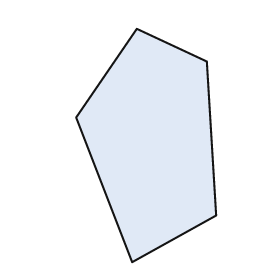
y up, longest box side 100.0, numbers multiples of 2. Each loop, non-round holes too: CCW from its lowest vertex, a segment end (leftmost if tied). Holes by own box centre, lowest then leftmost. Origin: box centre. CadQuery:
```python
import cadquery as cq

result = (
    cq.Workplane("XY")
    .moveTo(-6.0, -50.0)
    .lineTo(30.0, -30.0)
    .lineTo(26.0, 36.0)
    .lineTo(-4.0, 50.0)
    .lineTo(-30.0, 12.0)
    .close()
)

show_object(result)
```